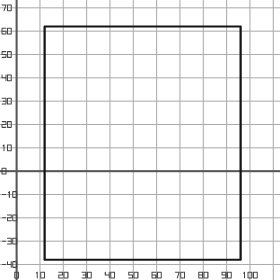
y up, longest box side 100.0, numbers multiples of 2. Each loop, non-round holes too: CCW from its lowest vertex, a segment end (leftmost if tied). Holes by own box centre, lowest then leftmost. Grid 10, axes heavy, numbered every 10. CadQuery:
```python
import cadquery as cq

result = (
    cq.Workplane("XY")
    .moveTo(12.0, -38.0)
    .lineTo(96.0, -38.0)
    .lineTo(96.0, 62.0)
    .lineTo(12.0, 62.0)
    .close()
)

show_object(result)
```